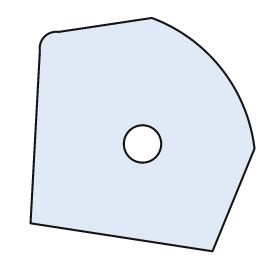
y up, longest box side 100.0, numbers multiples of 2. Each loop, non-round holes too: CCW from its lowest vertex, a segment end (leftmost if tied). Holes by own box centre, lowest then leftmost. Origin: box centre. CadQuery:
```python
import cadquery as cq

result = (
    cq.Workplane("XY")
    .moveTo(30.0, -50.0)
    .lineTo(48.0, -6.0)
    .threePointArc((34.0, 28.0), (4.0, 50.0))
    .lineTo(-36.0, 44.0)
    .threePointArc((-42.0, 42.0), (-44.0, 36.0))
    .lineTo(-48.0, -38.0)
    .close()
    .moveTo(0.0, -4.0)
    .circle(8.0)
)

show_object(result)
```